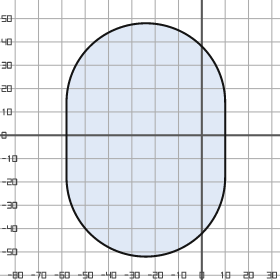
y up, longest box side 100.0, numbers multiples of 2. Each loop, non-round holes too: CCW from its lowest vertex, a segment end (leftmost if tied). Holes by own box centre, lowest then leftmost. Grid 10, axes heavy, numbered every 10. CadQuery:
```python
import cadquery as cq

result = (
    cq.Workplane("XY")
    .moveTo(-58.0, -18.0)
    .threePointArc((-24.0, -52.0), (10.0, -18.0))
    .lineTo(10.0, 14.0)
    .threePointArc((-24.0, 48.0), (-58.0, 14.0))
    .close()
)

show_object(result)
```